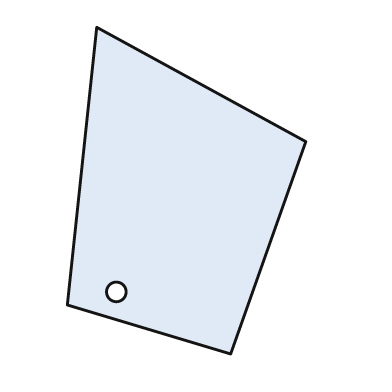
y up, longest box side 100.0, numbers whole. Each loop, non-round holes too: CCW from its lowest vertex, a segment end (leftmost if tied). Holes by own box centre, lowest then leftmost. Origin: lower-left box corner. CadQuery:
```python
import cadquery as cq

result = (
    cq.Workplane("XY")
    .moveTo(50.0, 0.0)
    .lineTo(73.0, 65.0)
    .lineTo(9.0, 100.0)
    .lineTo(0.0, 15.0)
    .close()
    .moveTo(15.0, 19.0)
    .circle(3.0)
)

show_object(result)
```